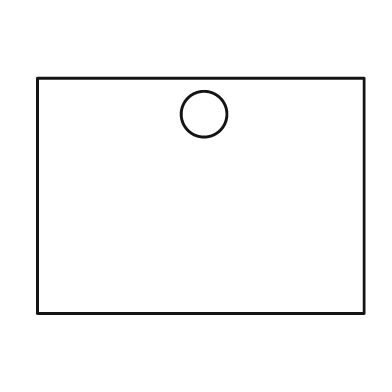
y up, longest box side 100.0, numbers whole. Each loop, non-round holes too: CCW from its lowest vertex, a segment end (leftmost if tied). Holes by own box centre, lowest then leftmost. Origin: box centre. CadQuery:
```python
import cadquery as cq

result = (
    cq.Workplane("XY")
    .moveTo(-50.0, -36.0)
    .lineTo(50.0, -36.0)
    .lineTo(50.0, 36.0)
    .lineTo(-50.0, 36.0)
    .close()
    .moveTo(1.0, 25.0)
    .circle(7.0)
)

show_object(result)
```